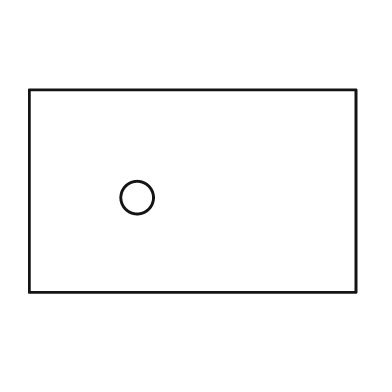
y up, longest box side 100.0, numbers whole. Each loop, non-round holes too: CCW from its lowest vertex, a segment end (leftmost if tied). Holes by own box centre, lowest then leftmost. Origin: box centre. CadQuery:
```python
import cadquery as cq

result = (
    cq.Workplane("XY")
    .moveTo(-50.0, -31.0)
    .lineTo(50.0, -31.0)
    .lineTo(50.0, 31.0)
    .lineTo(-50.0, 31.0)
    .close()
    .moveTo(-17.0, -2.0)
    .circle(5.0)
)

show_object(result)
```